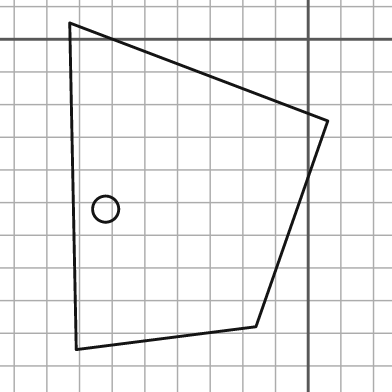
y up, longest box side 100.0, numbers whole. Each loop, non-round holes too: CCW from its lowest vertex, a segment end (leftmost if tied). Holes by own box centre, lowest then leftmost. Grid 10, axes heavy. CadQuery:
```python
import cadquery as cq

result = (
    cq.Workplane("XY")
    .moveTo(-71.0, -95.0)
    .lineTo(-16.0, -88.0)
    .lineTo(6.0, -25.0)
    .lineTo(-73.0, 5.0)
    .close()
    .moveTo(-62.0, -52.0)
    .circle(4.0)
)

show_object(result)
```